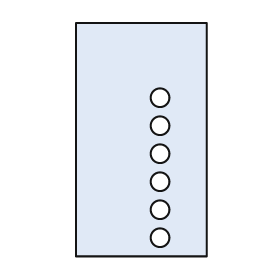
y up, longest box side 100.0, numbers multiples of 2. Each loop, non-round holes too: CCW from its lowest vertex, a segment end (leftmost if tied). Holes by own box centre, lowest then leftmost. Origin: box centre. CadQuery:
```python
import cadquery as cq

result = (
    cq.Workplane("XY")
    .moveTo(-28.0, -50.0)
    .lineTo(28.0, -50.0)
    .lineTo(28.0, 50.0)
    .lineTo(-28.0, 50.0)
    .close()
    .moveTo(8.0, -42.0)
    .circle(4.0)
    .moveTo(8.0, -30.0)
    .circle(4.0)
    .moveTo(8.0, -18.0)
    .circle(4.0)
    .moveTo(8.0, -6.0)
    .circle(4.0)
    .moveTo(8.0, 6.0)
    .circle(4.0)
    .moveTo(8.0, 18.0)
    .circle(4.0)
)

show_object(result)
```